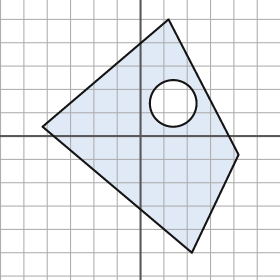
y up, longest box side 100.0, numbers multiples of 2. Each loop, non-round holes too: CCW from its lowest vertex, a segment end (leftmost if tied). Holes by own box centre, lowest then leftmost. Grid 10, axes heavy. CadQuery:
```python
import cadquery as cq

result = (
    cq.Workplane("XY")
    .moveTo(22.0, -50.0)
    .lineTo(42.0, -8.0)
    .lineTo(12.0, 50.0)
    .lineTo(-42.0, 4.0)
    .close()
    .moveTo(14.0, 14.0)
    .circle(10.0)
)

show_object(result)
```